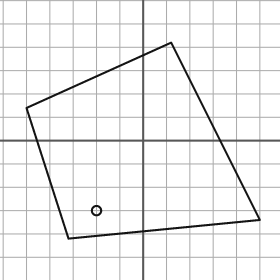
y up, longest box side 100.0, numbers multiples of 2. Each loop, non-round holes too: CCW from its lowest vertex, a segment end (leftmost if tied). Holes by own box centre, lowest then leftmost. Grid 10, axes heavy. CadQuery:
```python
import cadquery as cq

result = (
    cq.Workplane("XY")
    .moveTo(-32.0, -42.0)
    .lineTo(50.0, -34.0)
    .lineTo(12.0, 42.0)
    .lineTo(-50.0, 14.0)
    .close()
    .moveTo(-20.0, -30.0)
    .circle(2.0)
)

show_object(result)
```